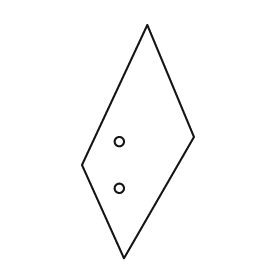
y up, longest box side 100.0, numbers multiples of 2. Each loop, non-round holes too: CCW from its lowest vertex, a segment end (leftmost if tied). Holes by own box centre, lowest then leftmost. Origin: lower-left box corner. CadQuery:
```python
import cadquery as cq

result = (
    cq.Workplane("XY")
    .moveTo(18.0, 0.0)
    .lineTo(48.0, 52.0)
    .lineTo(28.0, 100.0)
    .lineTo(0.0, 40.0)
    .close()
    .moveTo(16.0, 30.0)
    .circle(2.0)
    .moveTo(16.0, 50.0)
    .circle(2.0)
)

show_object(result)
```